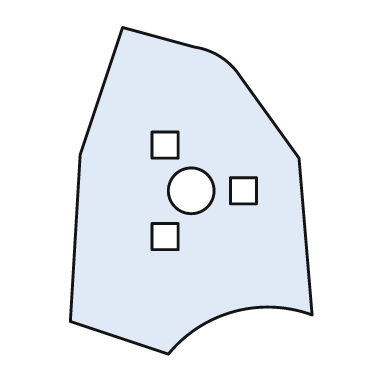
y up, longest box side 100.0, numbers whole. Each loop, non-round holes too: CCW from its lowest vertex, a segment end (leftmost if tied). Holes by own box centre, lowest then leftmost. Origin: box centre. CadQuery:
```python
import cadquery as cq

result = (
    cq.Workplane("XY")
    .moveTo(-7.0, -50.0)
    .threePointArc((13.0, -37.0), (37.0, -38.0))
    .lineTo(33.0, 10.0)
    .lineTo(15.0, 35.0)
    .threePointArc((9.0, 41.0), (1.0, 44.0))
    .lineTo(-21.0, 50.0)
    .lineTo(-34.0, 11.0)
    .lineTo(-37.0, -40.0)
    .close()
    .moveTo(-12.0, -18.0)
    .lineTo(-4.0, -18.0)
    .lineTo(-4.0, -10.0)
    .lineTo(-12.0, -10.0)
    .close()
    .moveTo(0.0, 0.0)
    .circle(7.0)
    .moveTo(12.0, -4.0)
    .lineTo(20.0, -4.0)
    .lineTo(20.0, 4.0)
    .lineTo(12.0, 4.0)
    .close()
    .moveTo(-12.0, 10.0)
    .lineTo(-4.0, 10.0)
    .lineTo(-4.0, 18.0)
    .lineTo(-12.0, 18.0)
    .close()
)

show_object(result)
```